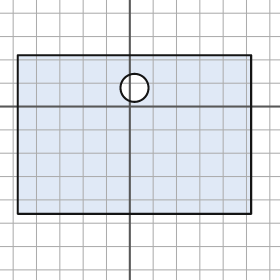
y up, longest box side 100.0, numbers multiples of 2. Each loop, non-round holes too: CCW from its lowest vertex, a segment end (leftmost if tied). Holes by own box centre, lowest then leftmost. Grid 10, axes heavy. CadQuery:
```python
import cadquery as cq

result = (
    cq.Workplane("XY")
    .moveTo(-48.0, -46.0)
    .lineTo(52.0, -46.0)
    .lineTo(52.0, 22.0)
    .lineTo(-48.0, 22.0)
    .close()
    .moveTo(2.0, 8.0)
    .circle(6.0)
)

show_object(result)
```